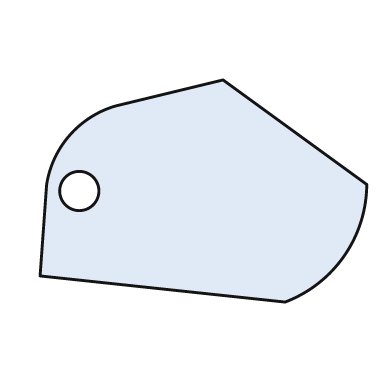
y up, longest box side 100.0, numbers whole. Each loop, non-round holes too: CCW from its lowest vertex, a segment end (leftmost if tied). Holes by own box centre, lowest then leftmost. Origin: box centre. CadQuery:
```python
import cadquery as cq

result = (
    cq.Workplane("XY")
    .moveTo(25.0, -34.0)
    .threePointArc((43.0, -20.0), (50.0, 2.0))
    .lineTo(6.0, 34.0)
    .lineTo(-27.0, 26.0)
    .threePointArc((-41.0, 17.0), (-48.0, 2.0))
    .lineTo(-50.0, -26.0)
    .close()
    .moveTo(-38.0, 0.0)
    .circle(6.0)
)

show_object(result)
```